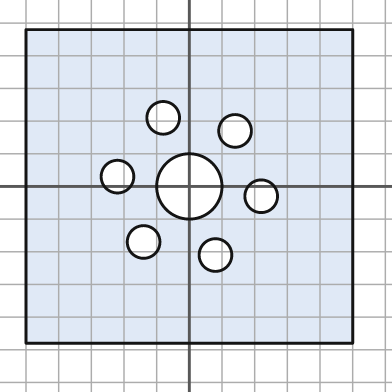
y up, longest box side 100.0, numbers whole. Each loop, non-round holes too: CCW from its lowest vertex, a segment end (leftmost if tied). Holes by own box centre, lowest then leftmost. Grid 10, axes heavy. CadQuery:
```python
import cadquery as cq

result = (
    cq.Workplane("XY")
    .moveTo(-50.0, -48.0)
    .lineTo(50.0, -48.0)
    .lineTo(50.0, 48.0)
    .lineTo(-50.0, 48.0)
    .close()
    .moveTo(8.0, -21.0)
    .circle(5.0)
    .moveTo(-14.0, -17.0)
    .circle(5.0)
    .moveTo(22.0, -3.0)
    .circle(5.0)
    .moveTo(0.0, 0.0)
    .circle(10.0)
    .moveTo(-22.0, 3.0)
    .circle(5.0)
    .moveTo(14.0, 17.0)
    .circle(5.0)
    .moveTo(-8.0, 21.0)
    .circle(5.0)
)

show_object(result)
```